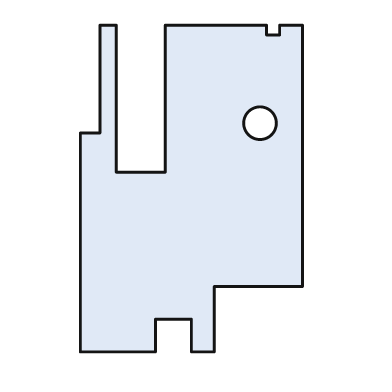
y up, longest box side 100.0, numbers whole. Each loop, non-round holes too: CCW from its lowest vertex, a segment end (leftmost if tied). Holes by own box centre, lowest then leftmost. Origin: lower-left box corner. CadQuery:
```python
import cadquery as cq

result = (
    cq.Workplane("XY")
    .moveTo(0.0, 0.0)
    .lineTo(23.0, 0.0)
    .lineTo(23.0, 10.0)
    .lineTo(34.0, 10.0)
    .lineTo(34.0, 0.0)
    .lineTo(41.0, 0.0)
    .lineTo(41.0, 20.0)
    .lineTo(68.0, 20.0)
    .lineTo(68.0, 100.0)
    .lineTo(61.0, 100.0)
    .lineTo(61.0, 97.0)
    .lineTo(57.0, 97.0)
    .lineTo(57.0, 100.0)
    .lineTo(26.0, 100.0)
    .lineTo(26.0, 55.0)
    .lineTo(11.0, 55.0)
    .lineTo(11.0, 100.0)
    .lineTo(6.0, 100.0)
    .lineTo(6.0, 67.0)
    .lineTo(0.0, 67.0)
    .close()
    .moveTo(55.0, 70.0)
    .circle(5.0)
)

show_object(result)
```